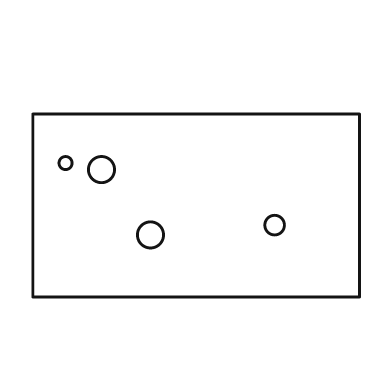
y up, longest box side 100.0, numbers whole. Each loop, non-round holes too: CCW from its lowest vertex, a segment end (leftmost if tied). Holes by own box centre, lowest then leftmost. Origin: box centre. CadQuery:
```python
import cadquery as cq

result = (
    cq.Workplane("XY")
    .moveTo(-50.0, -28.0)
    .lineTo(50.0, -28.0)
    .lineTo(50.0, 28.0)
    .lineTo(-50.0, 28.0)
    .close()
    .moveTo(-14.0, -9.0)
    .circle(4.0)
    .moveTo(24.0, -6.0)
    .circle(3.0)
    .moveTo(-29.0, 11.0)
    .circle(4.0)
    .moveTo(-40.0, 13.0)
    .circle(2.0)
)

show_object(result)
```